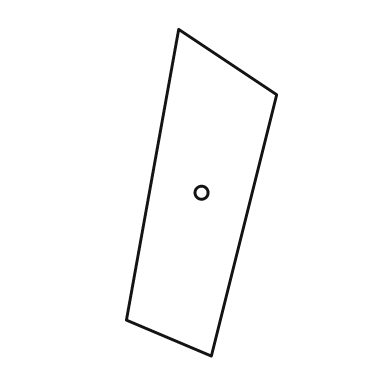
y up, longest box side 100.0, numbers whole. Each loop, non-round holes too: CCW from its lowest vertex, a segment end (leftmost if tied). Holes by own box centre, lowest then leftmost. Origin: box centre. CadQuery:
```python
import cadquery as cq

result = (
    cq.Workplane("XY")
    .moveTo(3.0, -50.0)
    .lineTo(23.0, 30.0)
    .lineTo(-7.0, 50.0)
    .lineTo(-23.0, -39.0)
    .close()
    .moveTo(0.0, 0.0)
    .circle(2.0)
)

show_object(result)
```